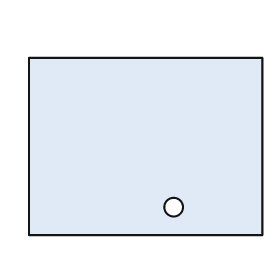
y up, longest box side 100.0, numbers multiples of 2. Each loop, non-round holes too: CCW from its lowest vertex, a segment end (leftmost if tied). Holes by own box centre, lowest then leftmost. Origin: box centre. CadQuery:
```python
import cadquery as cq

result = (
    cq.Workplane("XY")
    .moveTo(-50.0, -38.0)
    .lineTo(50.0, -38.0)
    .lineTo(50.0, 38.0)
    .lineTo(-50.0, 38.0)
    .close()
    .moveTo(12.0, -26.0)
    .circle(4.0)
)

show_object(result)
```